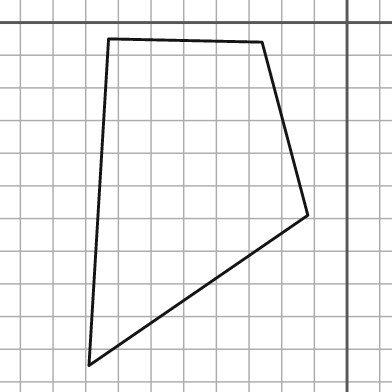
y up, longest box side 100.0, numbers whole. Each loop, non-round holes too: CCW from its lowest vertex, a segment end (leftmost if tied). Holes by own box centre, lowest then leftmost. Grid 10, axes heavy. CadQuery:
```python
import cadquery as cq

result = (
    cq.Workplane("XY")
    .moveTo(-79.0, -105.0)
    .lineTo(-12.0, -59.0)
    .lineTo(-26.0, -6.0)
    .lineTo(-73.0, -5.0)
    .close()
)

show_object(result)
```